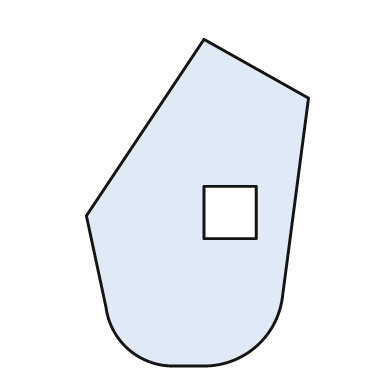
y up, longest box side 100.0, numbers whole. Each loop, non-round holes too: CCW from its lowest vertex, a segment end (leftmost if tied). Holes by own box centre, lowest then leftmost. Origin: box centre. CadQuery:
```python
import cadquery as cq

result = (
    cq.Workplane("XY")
    .moveTo(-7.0, -50.0)
    .lineTo(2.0, -50.0)
    .threePointArc((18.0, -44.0), (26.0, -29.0))
    .lineTo(34.0, 32.0)
    .lineTo(2.0, 50.0)
    .lineTo(-34.0, -4.0)
    .lineTo(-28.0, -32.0)
    .threePointArc((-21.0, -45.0), (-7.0, -50.0))
    .close()
    .moveTo(2.0, -11.0)
    .lineTo(18.0, -11.0)
    .lineTo(18.0, 5.0)
    .lineTo(2.0, 5.0)
    .close()
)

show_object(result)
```